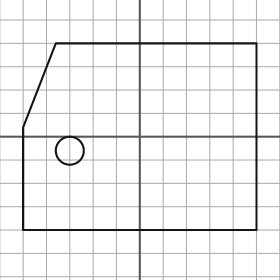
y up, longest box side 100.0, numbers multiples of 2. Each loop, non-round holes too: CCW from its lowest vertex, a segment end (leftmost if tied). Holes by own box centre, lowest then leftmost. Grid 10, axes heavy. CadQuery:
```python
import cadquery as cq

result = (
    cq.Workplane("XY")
    .moveTo(-50.0, -40.0)
    .lineTo(50.0, -40.0)
    .lineTo(50.0, 40.0)
    .lineTo(-36.0, 40.0)
    .lineTo(-50.0, 4.0)
    .close()
    .moveTo(-30.0, -6.0)
    .circle(6.0)
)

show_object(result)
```